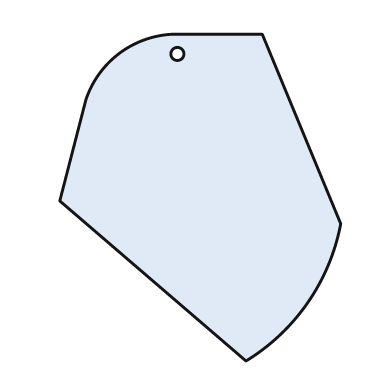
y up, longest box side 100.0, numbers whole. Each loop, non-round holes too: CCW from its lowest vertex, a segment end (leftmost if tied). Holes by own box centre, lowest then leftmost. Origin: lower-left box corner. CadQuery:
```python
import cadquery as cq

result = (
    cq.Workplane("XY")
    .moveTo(57.0, 0.0)
    .threePointArc((76.0, 18.0), (86.0, 42.0))
    .lineTo(62.0, 100.0)
    .lineTo(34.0, 100.0)
    .threePointArc((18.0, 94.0), (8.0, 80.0))
    .lineTo(0.0, 49.0)
    .close()
    .moveTo(36.0, 94.0)
    .circle(2.0)
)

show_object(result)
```